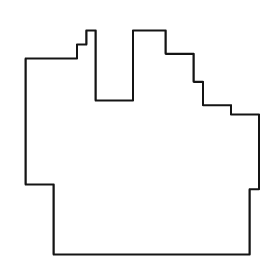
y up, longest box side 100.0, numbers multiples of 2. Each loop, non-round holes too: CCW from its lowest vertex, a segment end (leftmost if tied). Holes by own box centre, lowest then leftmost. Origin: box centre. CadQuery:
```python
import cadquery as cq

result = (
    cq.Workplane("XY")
    .moveTo(-38.0, -48.0)
    .lineTo(46.0, -48.0)
    .lineTo(46.0, -20.0)
    .lineTo(50.0, -20.0)
    .lineTo(50.0, 12.0)
    .lineTo(38.0, 12.0)
    .lineTo(38.0, 16.0)
    .lineTo(26.0, 16.0)
    .lineTo(26.0, 26.0)
    .lineTo(22.0, 26.0)
    .lineTo(22.0, 38.0)
    .lineTo(10.0, 38.0)
    .lineTo(10.0, 48.0)
    .lineTo(-4.0, 48.0)
    .lineTo(-4.0, 18.0)
    .lineTo(-20.0, 18.0)
    .lineTo(-20.0, 48.0)
    .lineTo(-24.0, 48.0)
    .lineTo(-24.0, 42.0)
    .lineTo(-28.0, 42.0)
    .lineTo(-28.0, 36.0)
    .lineTo(-50.0, 36.0)
    .lineTo(-50.0, -18.0)
    .lineTo(-38.0, -18.0)
    .close()
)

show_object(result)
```